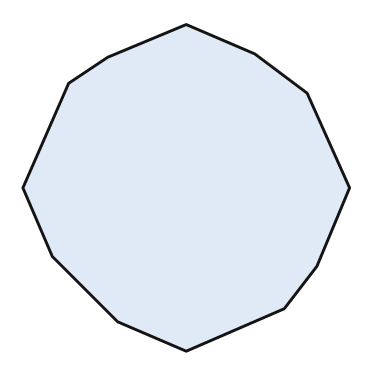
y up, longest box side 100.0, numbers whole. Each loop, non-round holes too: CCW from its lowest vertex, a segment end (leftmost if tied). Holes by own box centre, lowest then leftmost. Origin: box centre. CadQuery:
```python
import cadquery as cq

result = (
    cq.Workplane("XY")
    .moveTo(0.0, -50.0)
    .lineTo(30.0, -37.0)
    .lineTo(40.0, -24.0)
    .lineTo(50.0, 0.0)
    .lineTo(37.0, 29.0)
    .lineTo(21.0, 41.0)
    .lineTo(0.0, 50.0)
    .lineTo(-24.0, 40.0)
    .lineTo(-36.0, 32.0)
    .lineTo(-50.0, 0.0)
    .lineTo(-41.0, -21.0)
    .lineTo(-21.0, -41.0)
    .close()
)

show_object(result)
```